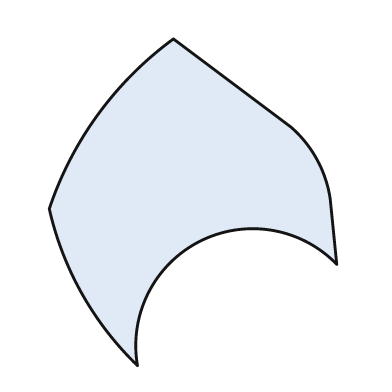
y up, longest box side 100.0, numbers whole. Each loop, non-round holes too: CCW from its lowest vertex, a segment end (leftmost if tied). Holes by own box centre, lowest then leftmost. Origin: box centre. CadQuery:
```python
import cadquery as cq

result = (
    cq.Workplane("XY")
    .moveTo(-17.0, -50.0)
    .threePointArc((2.0, -12.0), (44.0, -19.0))
    .lineTo(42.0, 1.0)
    .threePointArc((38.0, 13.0), (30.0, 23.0))
    .lineTo(-6.0, 50.0)
    .threePointArc((-29.0, 27.0), (-44.0, -2.0))
    .threePointArc((-34.0, -28.0), (-17.0, -50.0))
    .close()
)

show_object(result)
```